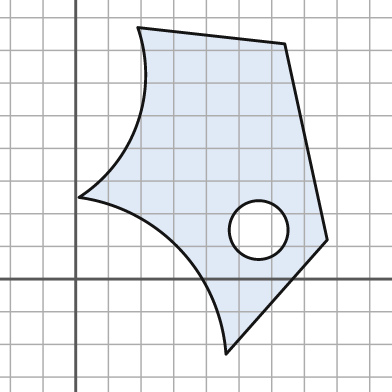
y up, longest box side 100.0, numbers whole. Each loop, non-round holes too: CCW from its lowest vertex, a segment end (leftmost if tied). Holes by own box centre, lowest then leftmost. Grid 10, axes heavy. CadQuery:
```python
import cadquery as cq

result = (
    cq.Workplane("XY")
    .moveTo(46.0, -23.0)
    .lineTo(77.0, 12.0)
    .lineTo(64.0, 72.0)
    .lineTo(19.0, 77.0)
    .threePointArc((19.0, 48.0), (1.0, 25.0))
    .threePointArc((32.0, 9.0), (46.0, -23.0))
    .close()
    .moveTo(56.0, 15.0)
    .circle(9.0)
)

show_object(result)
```